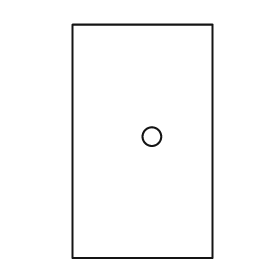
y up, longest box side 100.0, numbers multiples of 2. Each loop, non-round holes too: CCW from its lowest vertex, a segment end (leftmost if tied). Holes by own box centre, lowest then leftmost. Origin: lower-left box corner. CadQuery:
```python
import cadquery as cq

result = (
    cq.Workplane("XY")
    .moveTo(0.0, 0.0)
    .lineTo(60.0, 0.0)
    .lineTo(60.0, 100.0)
    .lineTo(0.0, 100.0)
    .close()
    .moveTo(34.0, 52.0)
    .circle(4.0)
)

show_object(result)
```